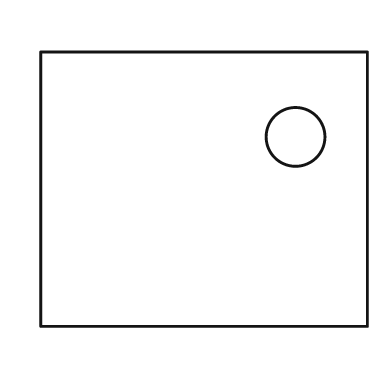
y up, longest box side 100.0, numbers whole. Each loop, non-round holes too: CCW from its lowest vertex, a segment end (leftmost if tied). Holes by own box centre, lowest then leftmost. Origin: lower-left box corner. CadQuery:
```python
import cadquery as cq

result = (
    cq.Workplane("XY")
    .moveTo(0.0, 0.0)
    .lineTo(100.0, 0.0)
    .lineTo(100.0, 84.0)
    .lineTo(0.0, 84.0)
    .close()
    .moveTo(78.0, 58.0)
    .circle(9.0)
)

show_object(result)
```